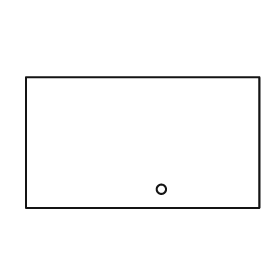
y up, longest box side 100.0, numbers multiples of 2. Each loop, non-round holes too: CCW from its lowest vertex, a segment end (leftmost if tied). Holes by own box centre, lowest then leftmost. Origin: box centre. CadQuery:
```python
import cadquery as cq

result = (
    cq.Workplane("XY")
    .moveTo(-50.0, -28.0)
    .lineTo(50.0, -28.0)
    .lineTo(50.0, 28.0)
    .lineTo(-50.0, 28.0)
    .close()
    .moveTo(8.0, -20.0)
    .circle(2.0)
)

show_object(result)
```